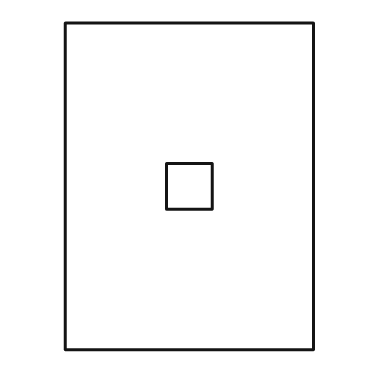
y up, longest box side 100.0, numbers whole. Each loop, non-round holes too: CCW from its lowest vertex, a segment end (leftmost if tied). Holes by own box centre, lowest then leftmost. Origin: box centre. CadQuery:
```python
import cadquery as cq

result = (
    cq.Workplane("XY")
    .moveTo(-38.0, -50.0)
    .lineTo(38.0, -50.0)
    .lineTo(38.0, 50.0)
    .lineTo(-38.0, 50.0)
    .close()
    .moveTo(-7.0, -7.0)
    .lineTo(7.0, -7.0)
    .lineTo(7.0, 7.0)
    .lineTo(-7.0, 7.0)
    .close()
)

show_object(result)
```